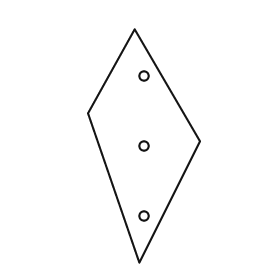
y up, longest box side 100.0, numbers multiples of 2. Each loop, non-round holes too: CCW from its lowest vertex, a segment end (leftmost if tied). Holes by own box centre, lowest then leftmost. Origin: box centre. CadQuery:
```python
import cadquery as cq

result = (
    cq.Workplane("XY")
    .moveTo(-2.0, -50.0)
    .lineTo(24.0, 2.0)
    .lineTo(-4.0, 50.0)
    .lineTo(-24.0, 14.0)
    .close()
    .moveTo(0.0, -30.0)
    .circle(2.0)
    .moveTo(0.0, 0.0)
    .circle(2.0)
    .moveTo(0.0, 30.0)
    .circle(2.0)
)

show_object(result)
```